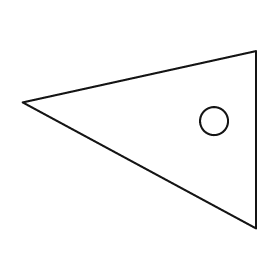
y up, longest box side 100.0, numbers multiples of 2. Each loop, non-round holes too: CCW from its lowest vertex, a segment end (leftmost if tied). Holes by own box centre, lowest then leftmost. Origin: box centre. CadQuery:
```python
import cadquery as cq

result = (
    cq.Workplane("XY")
    .moveTo(50.0, -38.0)
    .lineTo(50.0, 38.0)
    .lineTo(-50.0, 16.0)
    .close()
    .moveTo(32.0, 8.0)
    .circle(6.0)
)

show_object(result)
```